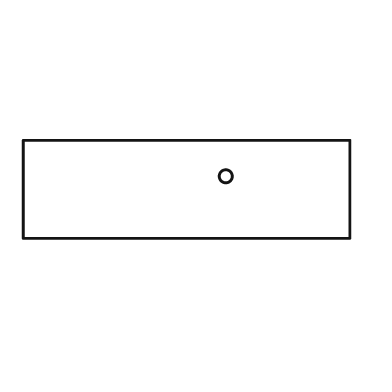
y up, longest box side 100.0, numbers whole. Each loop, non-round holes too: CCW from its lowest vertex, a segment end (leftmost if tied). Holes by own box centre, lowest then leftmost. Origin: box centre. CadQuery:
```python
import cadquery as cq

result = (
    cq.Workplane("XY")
    .moveTo(-50.0, -15.0)
    .lineTo(50.0, -15.0)
    .lineTo(50.0, 15.0)
    .lineTo(-50.0, 15.0)
    .close()
    .moveTo(12.0, 4.0)
    .circle(2.0)
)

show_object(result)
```